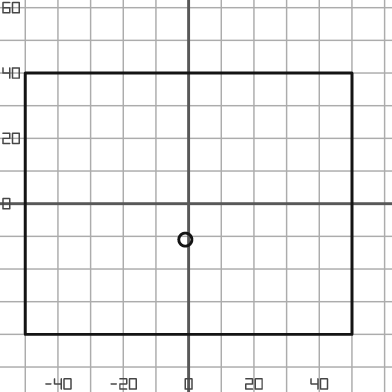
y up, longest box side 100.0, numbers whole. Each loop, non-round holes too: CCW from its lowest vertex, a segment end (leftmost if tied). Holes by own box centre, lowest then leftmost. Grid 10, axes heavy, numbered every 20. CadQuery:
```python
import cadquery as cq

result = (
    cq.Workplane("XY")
    .moveTo(-50.0, -40.0)
    .lineTo(50.0, -40.0)
    .lineTo(50.0, 40.0)
    .lineTo(-50.0, 40.0)
    .close()
    .moveTo(-1.0, -11.0)
    .circle(2.0)
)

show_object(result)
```